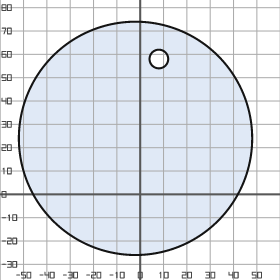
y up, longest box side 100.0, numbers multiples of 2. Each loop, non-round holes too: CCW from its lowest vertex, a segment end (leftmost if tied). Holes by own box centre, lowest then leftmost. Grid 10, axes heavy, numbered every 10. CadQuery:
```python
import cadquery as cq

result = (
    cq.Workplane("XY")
    .moveTo(-2.0, 24.0)
    .circle(50.0)
    .moveTo(8.0, 58.0)
    .circle(4.0)
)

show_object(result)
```